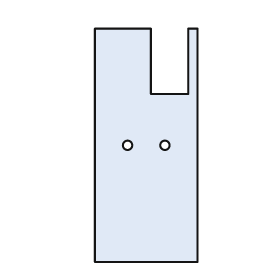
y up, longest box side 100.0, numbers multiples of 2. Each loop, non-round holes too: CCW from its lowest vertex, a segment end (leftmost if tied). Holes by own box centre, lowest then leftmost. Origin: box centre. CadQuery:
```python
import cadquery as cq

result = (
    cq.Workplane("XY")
    .moveTo(-22.0, -50.0)
    .lineTo(22.0, -50.0)
    .lineTo(22.0, 50.0)
    .lineTo(18.0, 50.0)
    .lineTo(18.0, 22.0)
    .lineTo(2.0, 22.0)
    .lineTo(2.0, 50.0)
    .lineTo(-22.0, 50.0)
    .close()
    .moveTo(-8.0, 0.0)
    .circle(2.0)
    .moveTo(8.0, 0.0)
    .circle(2.0)
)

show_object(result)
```